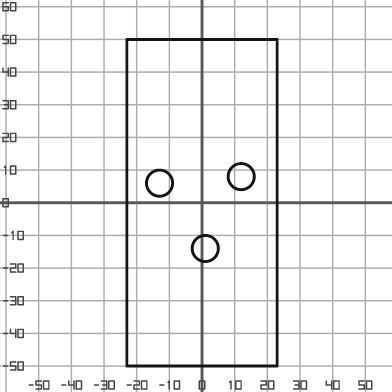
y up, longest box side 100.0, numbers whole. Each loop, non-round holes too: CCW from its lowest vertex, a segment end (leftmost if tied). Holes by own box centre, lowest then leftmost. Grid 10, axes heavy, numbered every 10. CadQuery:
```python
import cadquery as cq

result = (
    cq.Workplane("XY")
    .moveTo(-23.0, -50.0)
    .lineTo(23.0, -50.0)
    .lineTo(23.0, 50.0)
    .lineTo(-23.0, 50.0)
    .close()
    .moveTo(1.0, -14.0)
    .circle(4.0)
    .moveTo(-13.0, 6.0)
    .circle(4.0)
    .moveTo(12.0, 8.0)
    .circle(4.0)
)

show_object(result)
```